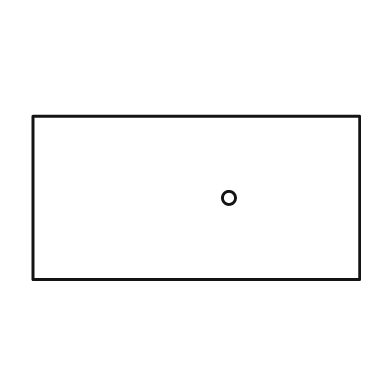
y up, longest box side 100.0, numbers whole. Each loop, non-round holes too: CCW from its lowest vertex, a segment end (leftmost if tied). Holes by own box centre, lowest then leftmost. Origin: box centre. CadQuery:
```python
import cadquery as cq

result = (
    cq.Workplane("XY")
    .moveTo(-50.0, -25.0)
    .lineTo(50.0, -25.0)
    .lineTo(50.0, 25.0)
    .lineTo(-50.0, 25.0)
    .close()
    .moveTo(10.0, 0.0)
    .circle(2.0)
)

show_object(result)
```